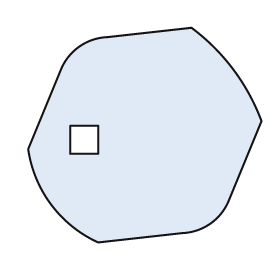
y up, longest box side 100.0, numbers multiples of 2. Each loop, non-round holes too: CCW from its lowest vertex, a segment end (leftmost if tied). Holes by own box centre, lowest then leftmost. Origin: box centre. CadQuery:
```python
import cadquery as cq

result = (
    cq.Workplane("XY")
    .moveTo(-20.0, -46.0)
    .lineTo(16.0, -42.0)
    .threePointArc((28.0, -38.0), (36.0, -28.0))
    .lineTo(50.0, 6.0)
    .threePointArc((38.0, 28.0), (20.0, 46.0))
    .lineTo(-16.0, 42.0)
    .threePointArc((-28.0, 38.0), (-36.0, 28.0))
    .lineTo(-50.0, -6.0)
    .threePointArc((-40.0, -30.0), (-20.0, -46.0))
    .close()
    .moveTo(-32.0, -8.0)
    .lineTo(-20.0, -8.0)
    .lineTo(-20.0, 4.0)
    .lineTo(-32.0, 4.0)
    .close()
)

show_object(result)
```